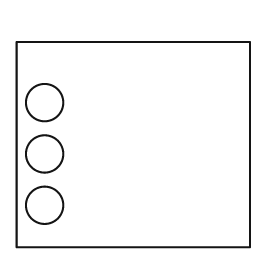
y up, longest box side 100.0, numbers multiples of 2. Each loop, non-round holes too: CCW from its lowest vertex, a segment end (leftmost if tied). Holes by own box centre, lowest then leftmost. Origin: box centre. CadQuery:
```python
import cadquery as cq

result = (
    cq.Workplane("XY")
    .moveTo(-50.0, -44.0)
    .lineTo(50.0, -44.0)
    .lineTo(50.0, 44.0)
    .lineTo(-50.0, 44.0)
    .close()
    .moveTo(-38.0, -26.0)
    .circle(8.0)
    .moveTo(-38.0, -4.0)
    .circle(8.0)
    .moveTo(-38.0, 18.0)
    .circle(8.0)
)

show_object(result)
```